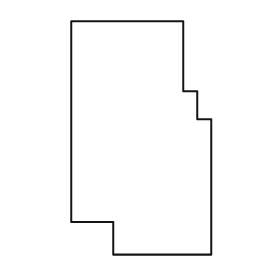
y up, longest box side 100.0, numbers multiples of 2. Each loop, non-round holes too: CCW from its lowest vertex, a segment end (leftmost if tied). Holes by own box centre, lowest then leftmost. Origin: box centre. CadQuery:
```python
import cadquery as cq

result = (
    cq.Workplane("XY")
    .moveTo(-12.0, -50.0)
    .lineTo(30.0, -50.0)
    .lineTo(30.0, 8.0)
    .lineTo(24.0, 8.0)
    .lineTo(24.0, 20.0)
    .lineTo(18.0, 20.0)
    .lineTo(18.0, 50.0)
    .lineTo(-30.0, 50.0)
    .lineTo(-30.0, -36.0)
    .lineTo(-12.0, -36.0)
    .close()
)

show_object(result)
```